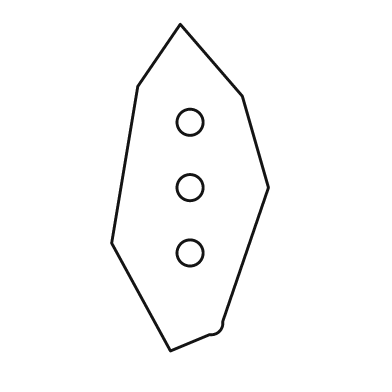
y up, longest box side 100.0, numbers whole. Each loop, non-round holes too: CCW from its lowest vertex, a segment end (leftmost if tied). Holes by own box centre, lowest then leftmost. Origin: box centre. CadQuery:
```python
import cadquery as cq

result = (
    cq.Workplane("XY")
    .moveTo(-6.0, -50.0)
    .lineTo(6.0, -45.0)
    .threePointArc((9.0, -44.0), (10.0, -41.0))
    .lineTo(24.0, 0.0)
    .lineTo(16.0, 28.0)
    .lineTo(-3.0, 50.0)
    .lineTo(-16.0, 31.0)
    .lineTo(-24.0, -17.0)
    .close()
    .moveTo(0.0, -20.0)
    .circle(4.0)
    .moveTo(0.0, 0.0)
    .circle(4.0)
    .moveTo(0.0, 20.0)
    .circle(4.0)
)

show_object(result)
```